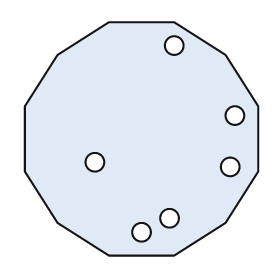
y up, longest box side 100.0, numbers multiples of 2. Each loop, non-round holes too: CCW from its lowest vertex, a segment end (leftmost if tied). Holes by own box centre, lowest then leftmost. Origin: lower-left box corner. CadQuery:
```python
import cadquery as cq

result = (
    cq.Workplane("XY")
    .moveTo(36.0, 0.0)
    .lineTo(64.0, 0.0)
    .lineTo(86.0, 14.0)
    .lineTo(100.0, 36.0)
    .lineTo(100.0, 64.0)
    .lineTo(86.0, 86.0)
    .lineTo(64.0, 100.0)
    .lineTo(36.0, 100.0)
    .lineTo(14.0, 86.0)
    .lineTo(0.0, 64.0)
    .lineTo(0.0, 36.0)
    .lineTo(14.0, 14.0)
    .close()
    .moveTo(50.0, 10.0)
    .circle(4.0)
    .moveTo(62.0, 16.0)
    .circle(4.0)
    .moveTo(88.0, 38.0)
    .circle(4.0)
    .moveTo(30.0, 40.0)
    .circle(4.0)
    .moveTo(90.0, 60.0)
    .circle(4.0)
    .moveTo(64.0, 90.0)
    .circle(4.0)
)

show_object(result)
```